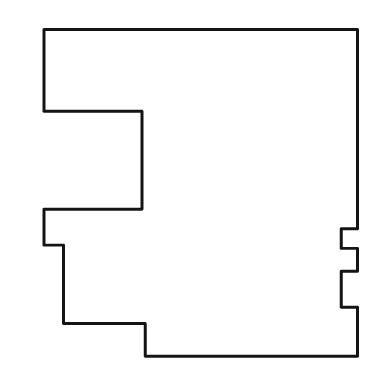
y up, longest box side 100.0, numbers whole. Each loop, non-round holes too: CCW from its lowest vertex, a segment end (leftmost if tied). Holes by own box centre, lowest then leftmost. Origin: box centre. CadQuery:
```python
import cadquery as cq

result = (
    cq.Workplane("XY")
    .moveTo(-17.0, -50.0)
    .lineTo(48.0, -50.0)
    .lineTo(48.0, -35.0)
    .lineTo(43.0, -35.0)
    .lineTo(43.0, -24.0)
    .lineTo(48.0, -24.0)
    .lineTo(48.0, -17.0)
    .lineTo(43.0, -17.0)
    .lineTo(43.0, -11.0)
    .lineTo(48.0, -11.0)
    .lineTo(48.0, 50.0)
    .lineTo(-48.0, 50.0)
    .lineTo(-48.0, 25.0)
    .lineTo(-18.0, 25.0)
    .lineTo(-18.0, -5.0)
    .lineTo(-48.0, -5.0)
    .lineTo(-48.0, -16.0)
    .lineTo(-42.0, -16.0)
    .lineTo(-42.0, -40.0)
    .lineTo(-17.0, -40.0)
    .close()
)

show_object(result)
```